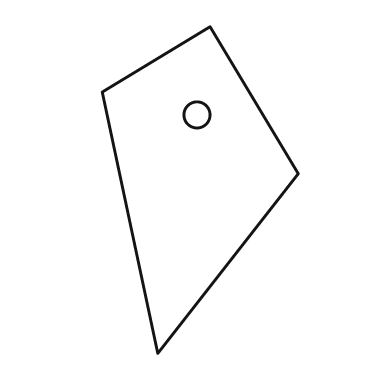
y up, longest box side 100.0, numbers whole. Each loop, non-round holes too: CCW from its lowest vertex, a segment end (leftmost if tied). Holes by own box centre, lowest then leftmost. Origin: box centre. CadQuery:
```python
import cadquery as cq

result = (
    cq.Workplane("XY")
    .moveTo(-13.0, -50.0)
    .lineTo(30.0, 5.0)
    .lineTo(3.0, 50.0)
    .lineTo(-30.0, 30.0)
    .close()
    .moveTo(-1.0, 23.0)
    .circle(4.0)
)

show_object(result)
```